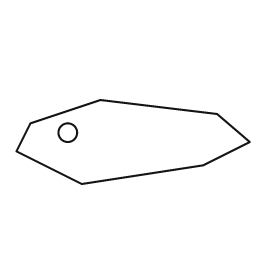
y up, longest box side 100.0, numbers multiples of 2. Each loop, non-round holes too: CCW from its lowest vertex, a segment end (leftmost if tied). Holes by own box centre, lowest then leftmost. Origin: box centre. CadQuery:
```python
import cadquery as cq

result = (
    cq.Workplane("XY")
    .moveTo(-22.0, -18.0)
    .lineTo(30.0, -10.0)
    .lineTo(50.0, 0.0)
    .lineTo(36.0, 12.0)
    .lineTo(-14.0, 18.0)
    .lineTo(-44.0, 8.0)
    .lineTo(-50.0, -4.0)
    .close()
    .moveTo(-28.0, 4.0)
    .circle(4.0)
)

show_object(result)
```